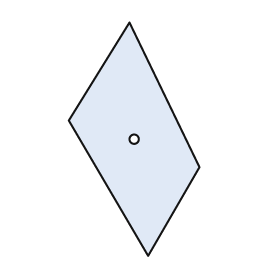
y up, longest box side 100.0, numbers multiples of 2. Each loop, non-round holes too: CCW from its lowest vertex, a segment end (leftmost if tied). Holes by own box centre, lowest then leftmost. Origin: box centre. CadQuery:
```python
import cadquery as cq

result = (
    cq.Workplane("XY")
    .moveTo(6.0, -50.0)
    .lineTo(28.0, -12.0)
    .lineTo(-2.0, 50.0)
    .lineTo(-28.0, 8.0)
    .close()
    .moveTo(0.0, 0.0)
    .circle(2.0)
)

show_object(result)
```